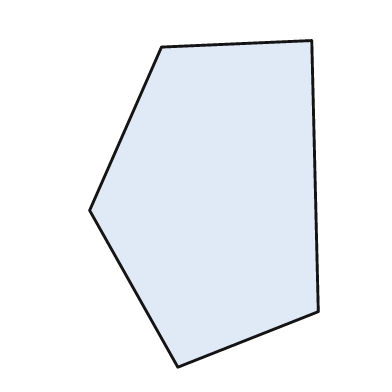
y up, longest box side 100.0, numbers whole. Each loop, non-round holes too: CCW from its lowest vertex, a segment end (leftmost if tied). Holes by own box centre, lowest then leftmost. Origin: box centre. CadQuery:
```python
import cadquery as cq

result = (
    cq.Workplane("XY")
    .moveTo(-8.0, -50.0)
    .lineTo(35.0, -33.0)
    .lineTo(33.0, 50.0)
    .lineTo(-13.0, 48.0)
    .lineTo(-35.0, -2.0)
    .close()
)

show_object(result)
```